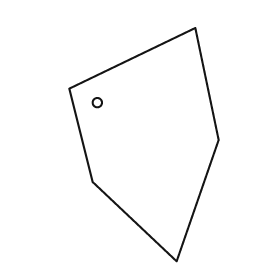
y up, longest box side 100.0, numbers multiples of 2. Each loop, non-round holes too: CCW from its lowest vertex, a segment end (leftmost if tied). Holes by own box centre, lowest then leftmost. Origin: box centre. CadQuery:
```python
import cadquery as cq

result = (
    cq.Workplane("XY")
    .moveTo(14.0, -50.0)
    .lineTo(32.0, 2.0)
    .lineTo(22.0, 50.0)
    .lineTo(-32.0, 24.0)
    .lineTo(-22.0, -16.0)
    .close()
    .moveTo(-20.0, 18.0)
    .circle(2.0)
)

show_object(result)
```